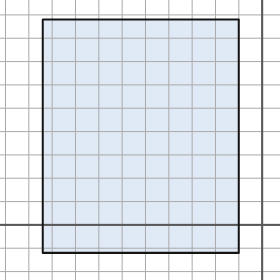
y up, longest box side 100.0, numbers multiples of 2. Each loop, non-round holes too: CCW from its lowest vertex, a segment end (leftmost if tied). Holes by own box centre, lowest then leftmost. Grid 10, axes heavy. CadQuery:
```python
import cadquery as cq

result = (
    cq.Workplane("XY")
    .moveTo(-94.0, -12.0)
    .lineTo(-10.0, -12.0)
    .lineTo(-10.0, 88.0)
    .lineTo(-94.0, 88.0)
    .close()
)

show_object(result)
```